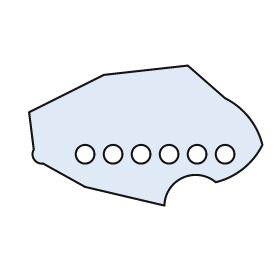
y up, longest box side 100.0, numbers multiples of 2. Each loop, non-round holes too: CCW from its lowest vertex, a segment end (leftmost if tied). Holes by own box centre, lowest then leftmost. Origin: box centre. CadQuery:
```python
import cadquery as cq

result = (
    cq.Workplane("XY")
    .moveTo(8.0, -30.0)
    .threePointArc((16.0, -18.0), (30.0, -20.0))
    .threePointArc((42.0, -14.0), (50.0, -4.0))
    .threePointArc((44.0, 8.0), (34.0, 16.0))
    .lineTo(18.0, 30.0)
    .lineTo(-18.0, 26.0)
    .lineTo(-50.0, 10.0)
    .lineTo(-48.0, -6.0)
    .threePointArc((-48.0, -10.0), (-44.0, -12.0))
    .lineTo(-26.0, -22.0)
    .close()
    .moveTo(-26.0, -8.0)
    .circle(4.0)
    .moveTo(-14.0, -8.0)
    .circle(4.0)
    .moveTo(-2.0, -8.0)
    .circle(4.0)
    .moveTo(10.0, -8.0)
    .circle(4.0)
    .moveTo(22.0, -8.0)
    .circle(4.0)
    .moveTo(34.0, -8.0)
    .circle(4.0)
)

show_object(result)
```